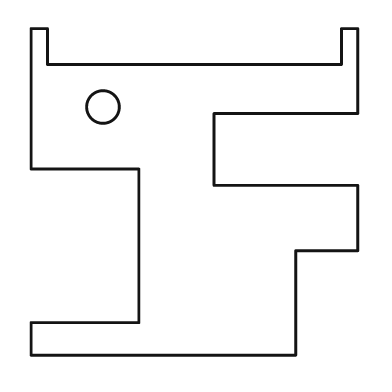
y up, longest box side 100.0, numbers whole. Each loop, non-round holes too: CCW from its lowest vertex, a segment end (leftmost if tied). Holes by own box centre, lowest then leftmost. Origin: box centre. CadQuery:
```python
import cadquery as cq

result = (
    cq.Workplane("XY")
    .moveTo(-50.0, -50.0)
    .lineTo(31.0, -50.0)
    .lineTo(31.0, -18.0)
    .lineTo(50.0, -18.0)
    .lineTo(50.0, 2.0)
    .lineTo(6.0, 2.0)
    .lineTo(6.0, 24.0)
    .lineTo(50.0, 24.0)
    .lineTo(50.0, 50.0)
    .lineTo(45.0, 50.0)
    .lineTo(45.0, 39.0)
    .lineTo(-45.0, 39.0)
    .lineTo(-45.0, 50.0)
    .lineTo(-50.0, 50.0)
    .lineTo(-50.0, 7.0)
    .lineTo(-17.0, 7.0)
    .lineTo(-17.0, -40.0)
    .lineTo(-50.0, -40.0)
    .close()
    .moveTo(-28.0, 26.0)
    .circle(5.0)
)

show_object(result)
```